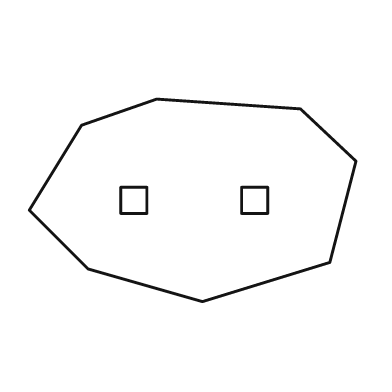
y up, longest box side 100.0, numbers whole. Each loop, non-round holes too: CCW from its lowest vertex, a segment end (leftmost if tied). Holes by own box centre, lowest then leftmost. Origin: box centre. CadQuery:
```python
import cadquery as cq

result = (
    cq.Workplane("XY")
    .moveTo(3.0, -31.0)
    .lineTo(42.0, -19.0)
    .lineTo(50.0, 12.0)
    .lineTo(33.0, 28.0)
    .lineTo(-11.0, 31.0)
    .lineTo(-34.0, 23.0)
    .lineTo(-50.0, -3.0)
    .lineTo(-32.0, -21.0)
    .close()
    .moveTo(-22.0, -4.0)
    .lineTo(-14.0, -4.0)
    .lineTo(-14.0, 4.0)
    .lineTo(-22.0, 4.0)
    .close()
    .moveTo(15.0, -4.0)
    .lineTo(23.0, -4.0)
    .lineTo(23.0, 4.0)
    .lineTo(15.0, 4.0)
    .close()
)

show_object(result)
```